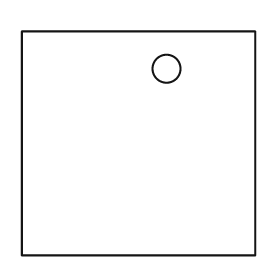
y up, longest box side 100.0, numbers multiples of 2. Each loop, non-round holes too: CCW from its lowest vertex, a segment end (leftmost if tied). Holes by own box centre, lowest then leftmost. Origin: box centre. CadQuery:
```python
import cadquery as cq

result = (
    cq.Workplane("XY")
    .moveTo(-50.0, -48.0)
    .lineTo(50.0, -48.0)
    .lineTo(50.0, 48.0)
    .lineTo(-50.0, 48.0)
    .close()
    .moveTo(12.0, 32.0)
    .circle(6.0)
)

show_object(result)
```